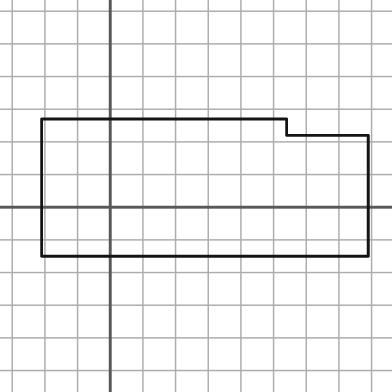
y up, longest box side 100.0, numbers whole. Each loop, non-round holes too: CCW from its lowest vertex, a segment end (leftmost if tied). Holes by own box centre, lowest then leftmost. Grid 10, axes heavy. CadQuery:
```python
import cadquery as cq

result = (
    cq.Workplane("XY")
    .moveTo(-21.0, -15.0)
    .lineTo(79.0, -15.0)
    .lineTo(79.0, 22.0)
    .lineTo(54.0, 22.0)
    .lineTo(54.0, 27.0)
    .lineTo(-21.0, 27.0)
    .close()
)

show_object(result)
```